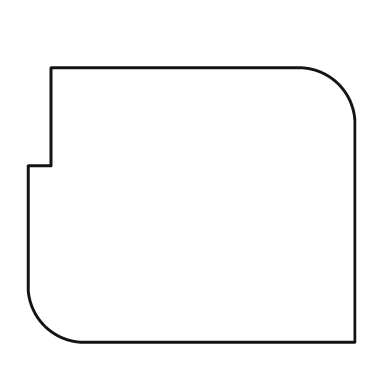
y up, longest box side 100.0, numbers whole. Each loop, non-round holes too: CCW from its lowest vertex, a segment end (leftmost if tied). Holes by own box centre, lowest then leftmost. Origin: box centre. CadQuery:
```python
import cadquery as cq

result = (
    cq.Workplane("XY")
    .moveTo(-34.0, -42.0)
    .lineTo(50.0, -42.0)
    .lineTo(50.0, 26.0)
    .threePointArc((45.0, 37.0), (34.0, 42.0))
    .lineTo(-43.0, 42.0)
    .lineTo(-43.0, 12.0)
    .lineTo(-50.0, 12.0)
    .lineTo(-50.0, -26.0)
    .threePointArc((-45.0, -37.0), (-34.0, -42.0))
    .close()
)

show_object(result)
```